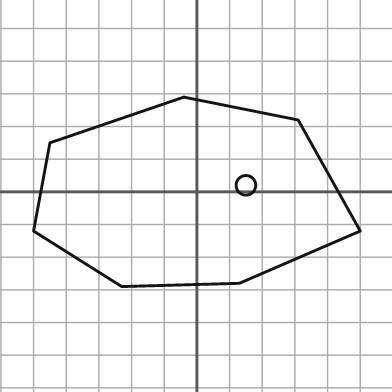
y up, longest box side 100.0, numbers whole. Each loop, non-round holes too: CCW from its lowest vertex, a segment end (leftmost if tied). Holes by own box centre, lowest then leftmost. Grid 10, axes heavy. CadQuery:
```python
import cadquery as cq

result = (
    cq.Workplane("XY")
    .moveTo(-23.0, -29.0)
    .lineTo(13.0, -28.0)
    .lineTo(50.0, -12.0)
    .lineTo(31.0, 22.0)
    .lineTo(-4.0, 29.0)
    .lineTo(-45.0, 15.0)
    .lineTo(-50.0, -12.0)
    .close()
    .moveTo(15.0, 2.0)
    .circle(3.0)
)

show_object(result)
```